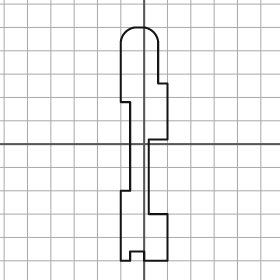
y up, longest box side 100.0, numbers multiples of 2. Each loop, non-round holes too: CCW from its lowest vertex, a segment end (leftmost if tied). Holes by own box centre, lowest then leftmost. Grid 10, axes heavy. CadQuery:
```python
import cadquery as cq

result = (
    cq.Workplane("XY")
    .moveTo(-10.0, -50.0)
    .lineTo(-6.0, -50.0)
    .lineTo(-6.0, -46.0)
    .lineTo(0.0, -46.0)
    .lineTo(0.0, -50.0)
    .lineTo(10.0, -50.0)
    .lineTo(10.0, -30.0)
    .lineTo(2.0, -30.0)
    .lineTo(2.0, 2.0)
    .lineTo(10.0, 2.0)
    .lineTo(10.0, 26.0)
    .lineTo(6.0, 26.0)
    .lineTo(6.0, 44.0)
    .threePointArc((4.0, 48.0), (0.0, 50.0))
    .lineTo(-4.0, 50.0)
    .threePointArc((-8.0, 48.0), (-10.0, 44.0))
    .lineTo(-10.0, 18.0)
    .lineTo(-6.0, 18.0)
    .lineTo(-6.0, -20.0)
    .lineTo(-10.0, -20.0)
    .close()
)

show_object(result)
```